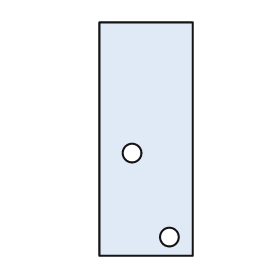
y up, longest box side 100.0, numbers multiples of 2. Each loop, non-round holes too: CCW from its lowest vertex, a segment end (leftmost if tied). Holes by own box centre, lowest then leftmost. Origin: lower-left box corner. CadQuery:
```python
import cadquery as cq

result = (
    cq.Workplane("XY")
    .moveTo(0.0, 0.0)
    .lineTo(40.0, 0.0)
    .lineTo(40.0, 100.0)
    .lineTo(0.0, 100.0)
    .close()
    .moveTo(30.0, 8.0)
    .circle(4.0)
    .moveTo(14.0, 44.0)
    .circle(4.0)
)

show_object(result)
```